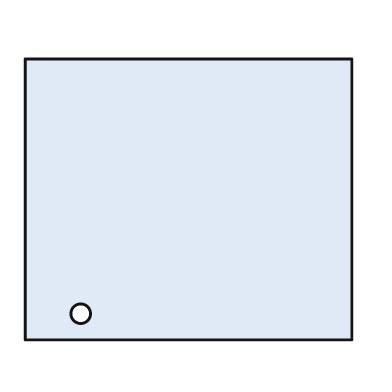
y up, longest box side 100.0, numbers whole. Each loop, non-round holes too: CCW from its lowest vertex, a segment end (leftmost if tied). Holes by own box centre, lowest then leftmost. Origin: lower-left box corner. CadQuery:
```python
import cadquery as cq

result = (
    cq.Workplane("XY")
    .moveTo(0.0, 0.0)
    .lineTo(100.0, 0.0)
    .lineTo(100.0, 86.0)
    .lineTo(0.0, 86.0)
    .close()
    .moveTo(17.0, 8.0)
    .circle(3.0)
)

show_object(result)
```